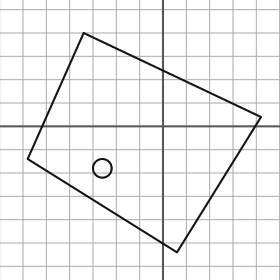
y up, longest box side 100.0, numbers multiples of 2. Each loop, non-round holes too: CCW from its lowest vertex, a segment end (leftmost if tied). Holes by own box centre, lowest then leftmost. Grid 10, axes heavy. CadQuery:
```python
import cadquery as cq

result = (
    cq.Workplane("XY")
    .moveTo(6.0, -54.0)
    .lineTo(42.0, 4.0)
    .lineTo(-34.0, 40.0)
    .lineTo(-58.0, -14.0)
    .close()
    .moveTo(-26.0, -18.0)
    .circle(4.0)
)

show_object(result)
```